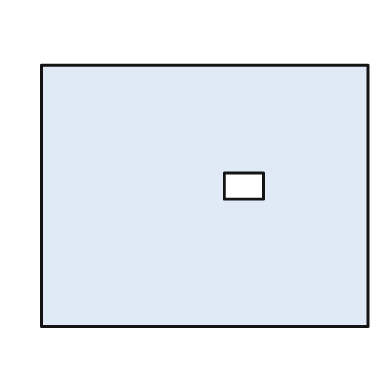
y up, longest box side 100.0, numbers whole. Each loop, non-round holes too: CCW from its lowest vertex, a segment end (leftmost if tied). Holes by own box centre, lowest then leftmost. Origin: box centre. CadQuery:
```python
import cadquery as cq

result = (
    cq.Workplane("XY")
    .moveTo(-50.0, -40.0)
    .lineTo(50.0, -40.0)
    .lineTo(50.0, 40.0)
    .lineTo(-50.0, 40.0)
    .close()
    .moveTo(6.0, -1.0)
    .lineTo(18.0, -1.0)
    .lineTo(18.0, 7.0)
    .lineTo(6.0, 7.0)
    .close()
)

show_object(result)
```